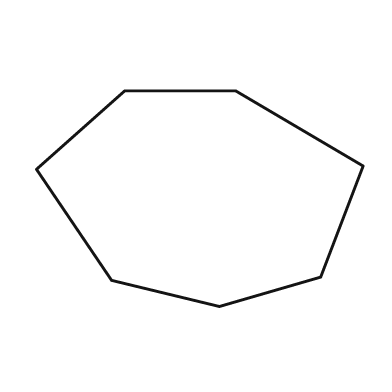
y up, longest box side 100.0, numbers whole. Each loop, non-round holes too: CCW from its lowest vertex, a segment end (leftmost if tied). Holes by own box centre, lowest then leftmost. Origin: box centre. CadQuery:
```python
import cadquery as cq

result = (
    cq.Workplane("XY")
    .moveTo(6.0, -33.0)
    .lineTo(37.0, -24.0)
    .lineTo(50.0, 10.0)
    .lineTo(11.0, 33.0)
    .lineTo(-23.0, 33.0)
    .lineTo(-50.0, 9.0)
    .lineTo(-27.0, -25.0)
    .close()
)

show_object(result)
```